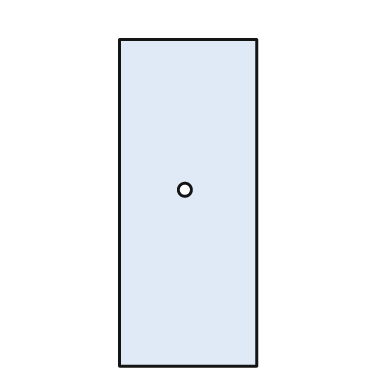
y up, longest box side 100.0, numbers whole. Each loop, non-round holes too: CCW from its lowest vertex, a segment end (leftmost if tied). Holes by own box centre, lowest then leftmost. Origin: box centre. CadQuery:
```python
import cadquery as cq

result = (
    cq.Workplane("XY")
    .moveTo(-21.0, -50.0)
    .lineTo(21.0, -50.0)
    .lineTo(21.0, 50.0)
    .lineTo(-21.0, 50.0)
    .close()
    .moveTo(-1.0, 4.0)
    .circle(2.0)
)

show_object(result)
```